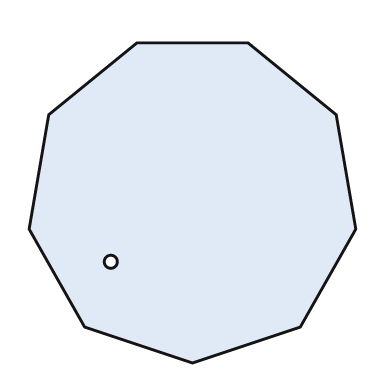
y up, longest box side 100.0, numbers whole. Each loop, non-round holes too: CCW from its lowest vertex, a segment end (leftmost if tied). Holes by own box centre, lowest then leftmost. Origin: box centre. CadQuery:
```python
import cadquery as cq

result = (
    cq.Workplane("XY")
    .moveTo(0.0, -49.0)
    .lineTo(33.0, -38.0)
    .lineTo(50.0, -8.0)
    .lineTo(44.0, 27.0)
    .lineTo(17.0, 49.0)
    .lineTo(-17.0, 49.0)
    .lineTo(-44.0, 27.0)
    .lineTo(-50.0, -8.0)
    .lineTo(-33.0, -38.0)
    .close()
    .moveTo(-25.0, -18.0)
    .circle(2.0)
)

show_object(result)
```